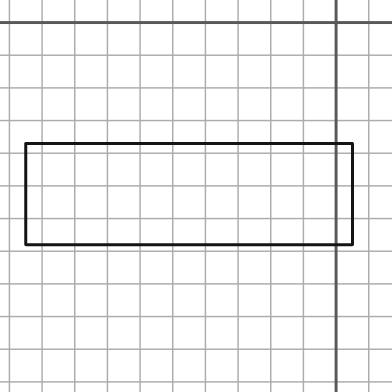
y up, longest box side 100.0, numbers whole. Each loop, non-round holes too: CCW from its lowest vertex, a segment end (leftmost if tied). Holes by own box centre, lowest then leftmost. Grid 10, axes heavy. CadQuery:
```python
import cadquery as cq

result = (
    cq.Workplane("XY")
    .moveTo(-95.0, -68.0)
    .lineTo(5.0, -68.0)
    .lineTo(5.0, -37.0)
    .lineTo(-95.0, -37.0)
    .close()
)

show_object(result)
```